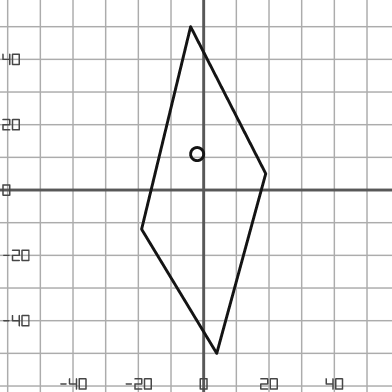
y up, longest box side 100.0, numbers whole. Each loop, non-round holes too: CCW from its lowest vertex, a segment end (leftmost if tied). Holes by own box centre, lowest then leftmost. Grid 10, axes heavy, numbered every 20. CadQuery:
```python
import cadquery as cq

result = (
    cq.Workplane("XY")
    .moveTo(4.0, -50.0)
    .lineTo(19.0, 5.0)
    .lineTo(-4.0, 50.0)
    .lineTo(-19.0, -12.0)
    .close()
    .moveTo(-2.0, 11.0)
    .circle(2.0)
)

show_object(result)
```